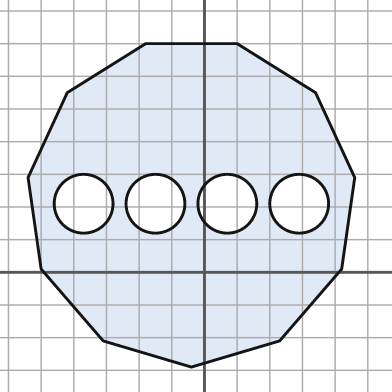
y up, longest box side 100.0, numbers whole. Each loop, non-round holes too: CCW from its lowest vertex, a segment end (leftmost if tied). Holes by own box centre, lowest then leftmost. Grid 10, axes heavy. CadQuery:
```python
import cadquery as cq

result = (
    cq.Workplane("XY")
    .moveTo(-4.0, -29.0)
    .lineTo(23.0, -21.0)
    .lineTo(42.0, 1.0)
    .lineTo(46.0, 29.0)
    .lineTo(34.0, 55.0)
    .lineTo(10.0, 70.0)
    .lineTo(-18.0, 70.0)
    .lineTo(-42.0, 55.0)
    .lineTo(-54.0, 29.0)
    .lineTo(-50.0, 1.0)
    .lineTo(-31.0, -21.0)
    .close()
    .moveTo(-37.0, 21.0)
    .circle(9.0)
    .moveTo(-15.0, 21.0)
    .circle(9.0)
    .moveTo(7.0, 21.0)
    .circle(9.0)
    .moveTo(29.0, 21.0)
    .circle(9.0)
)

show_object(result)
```